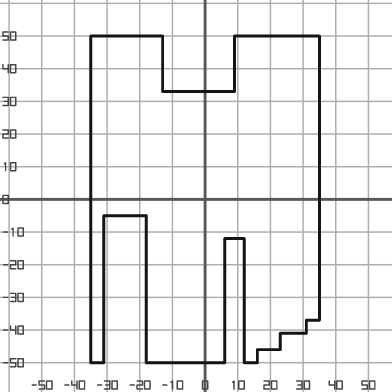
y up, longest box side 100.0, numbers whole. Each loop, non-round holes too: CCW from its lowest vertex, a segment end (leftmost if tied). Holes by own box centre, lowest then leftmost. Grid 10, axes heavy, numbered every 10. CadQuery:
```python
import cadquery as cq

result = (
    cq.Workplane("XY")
    .moveTo(-35.0, -50.0)
    .lineTo(-31.0, -50.0)
    .lineTo(-31.0, -5.0)
    .lineTo(-18.0, -5.0)
    .lineTo(-18.0, -50.0)
    .lineTo(6.0, -50.0)
    .lineTo(6.0, -12.0)
    .lineTo(12.0, -12.0)
    .lineTo(12.0, -50.0)
    .lineTo(16.0, -50.0)
    .lineTo(16.0, -46.0)
    .lineTo(23.0, -46.0)
    .lineTo(23.0, -41.0)
    .lineTo(31.0, -41.0)
    .lineTo(31.0, -37.0)
    .lineTo(35.0, -37.0)
    .lineTo(35.0, 50.0)
    .lineTo(9.0, 50.0)
    .lineTo(9.0, 33.0)
    .lineTo(-13.0, 33.0)
    .lineTo(-13.0, 50.0)
    .lineTo(-35.0, 50.0)
    .close()
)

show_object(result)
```